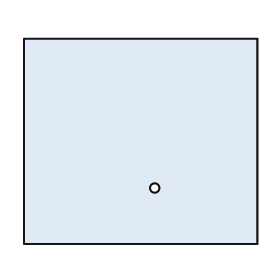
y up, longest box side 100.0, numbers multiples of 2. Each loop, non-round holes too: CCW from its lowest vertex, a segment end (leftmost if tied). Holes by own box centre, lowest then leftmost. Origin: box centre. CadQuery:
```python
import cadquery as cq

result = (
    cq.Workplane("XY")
    .moveTo(-50.0, -44.0)
    .lineTo(50.0, -44.0)
    .lineTo(50.0, 44.0)
    .lineTo(-50.0, 44.0)
    .close()
    .moveTo(6.0, -20.0)
    .circle(2.0)
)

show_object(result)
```